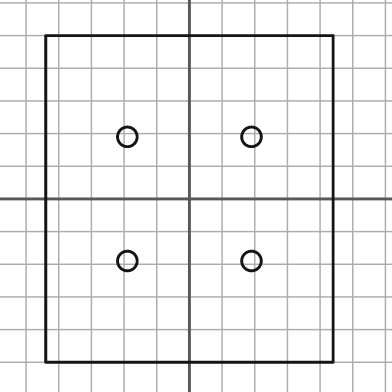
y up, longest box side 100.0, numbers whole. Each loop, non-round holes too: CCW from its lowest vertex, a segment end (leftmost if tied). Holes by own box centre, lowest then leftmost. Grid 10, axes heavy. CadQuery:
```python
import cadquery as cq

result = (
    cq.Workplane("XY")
    .moveTo(-44.0, -50.0)
    .lineTo(44.0, -50.0)
    .lineTo(44.0, 50.0)
    .lineTo(-44.0, 50.0)
    .close()
    .moveTo(-19.0, -19.0)
    .circle(3.0)
    .moveTo(19.0, -19.0)
    .circle(3.0)
    .moveTo(-19.0, 19.0)
    .circle(3.0)
    .moveTo(19.0, 19.0)
    .circle(3.0)
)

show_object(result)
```